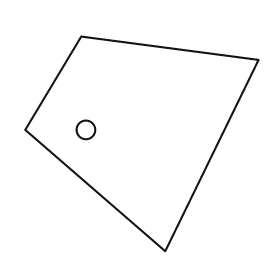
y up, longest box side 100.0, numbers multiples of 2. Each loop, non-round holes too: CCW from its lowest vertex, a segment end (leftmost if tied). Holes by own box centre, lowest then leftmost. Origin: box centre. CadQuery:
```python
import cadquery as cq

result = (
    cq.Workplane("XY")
    .moveTo(10.0, -46.0)
    .lineTo(50.0, 36.0)
    .lineTo(-26.0, 46.0)
    .lineTo(-50.0, 6.0)
    .close()
    .moveTo(-24.0, 6.0)
    .circle(4.0)
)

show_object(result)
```